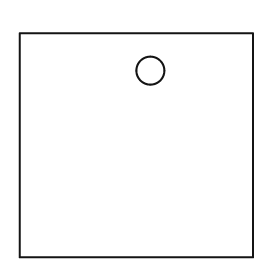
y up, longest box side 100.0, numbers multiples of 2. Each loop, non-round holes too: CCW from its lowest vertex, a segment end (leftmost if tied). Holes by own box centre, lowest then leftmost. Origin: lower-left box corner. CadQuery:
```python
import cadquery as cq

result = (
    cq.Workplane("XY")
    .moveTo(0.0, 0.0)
    .lineTo(100.0, 0.0)
    .lineTo(100.0, 96.0)
    .lineTo(0.0, 96.0)
    .close()
    .moveTo(56.0, 80.0)
    .circle(6.0)
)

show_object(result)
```